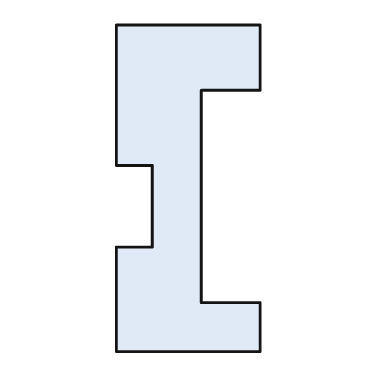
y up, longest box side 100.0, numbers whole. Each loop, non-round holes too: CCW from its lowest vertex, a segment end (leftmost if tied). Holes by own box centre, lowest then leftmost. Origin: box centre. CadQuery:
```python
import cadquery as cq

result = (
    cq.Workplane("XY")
    .moveTo(-22.0, -50.0)
    .lineTo(22.0, -50.0)
    .lineTo(22.0, -35.0)
    .lineTo(4.0, -35.0)
    .lineTo(4.0, 30.0)
    .lineTo(22.0, 30.0)
    .lineTo(22.0, 50.0)
    .lineTo(-22.0, 50.0)
    .lineTo(-22.0, 7.0)
    .lineTo(-11.0, 7.0)
    .lineTo(-11.0, -18.0)
    .lineTo(-22.0, -18.0)
    .close()
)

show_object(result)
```